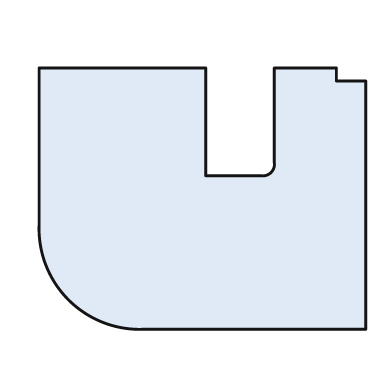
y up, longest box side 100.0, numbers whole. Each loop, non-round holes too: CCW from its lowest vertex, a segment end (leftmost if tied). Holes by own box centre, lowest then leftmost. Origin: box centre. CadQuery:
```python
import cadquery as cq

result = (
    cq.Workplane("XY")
    .moveTo(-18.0, -40.0)
    .lineTo(50.0, -40.0)
    .lineTo(50.0, 36.0)
    .lineTo(41.0, 36.0)
    .lineTo(41.0, 40.0)
    .lineTo(22.0, 40.0)
    .lineTo(22.0, 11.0)
    .threePointArc((21.0, 8.0), (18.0, 7.0))
    .lineTo(1.0, 7.0)
    .lineTo(1.0, 40.0)
    .lineTo(-50.0, 40.0)
    .lineTo(-50.0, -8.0)
    .threePointArc((-41.0, -31.0), (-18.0, -40.0))
    .close()
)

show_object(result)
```